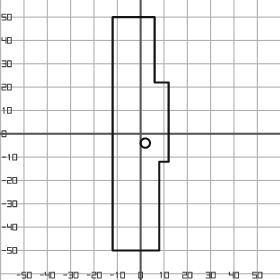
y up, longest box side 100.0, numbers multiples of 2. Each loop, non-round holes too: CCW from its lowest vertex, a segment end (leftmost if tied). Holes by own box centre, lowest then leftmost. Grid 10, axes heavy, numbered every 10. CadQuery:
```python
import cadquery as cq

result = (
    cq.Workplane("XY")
    .moveTo(-12.0, -50.0)
    .lineTo(8.0, -50.0)
    .lineTo(8.0, -12.0)
    .lineTo(12.0, -12.0)
    .lineTo(12.0, 22.0)
    .lineTo(6.0, 22.0)
    .lineTo(6.0, 50.0)
    .lineTo(-12.0, 50.0)
    .close()
    .moveTo(2.0, -4.0)
    .circle(2.0)
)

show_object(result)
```